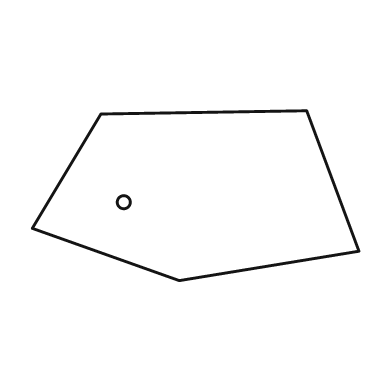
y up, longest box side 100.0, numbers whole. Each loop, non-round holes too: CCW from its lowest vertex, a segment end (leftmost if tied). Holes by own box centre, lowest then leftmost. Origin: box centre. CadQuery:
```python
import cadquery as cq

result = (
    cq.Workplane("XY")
    .moveTo(-5.0, -26.0)
    .lineTo(50.0, -17.0)
    .lineTo(34.0, 26.0)
    .lineTo(-29.0, 25.0)
    .lineTo(-50.0, -10.0)
    .close()
    .moveTo(-22.0, -2.0)
    .circle(2.0)
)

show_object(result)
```